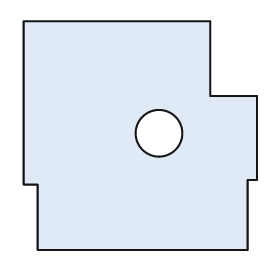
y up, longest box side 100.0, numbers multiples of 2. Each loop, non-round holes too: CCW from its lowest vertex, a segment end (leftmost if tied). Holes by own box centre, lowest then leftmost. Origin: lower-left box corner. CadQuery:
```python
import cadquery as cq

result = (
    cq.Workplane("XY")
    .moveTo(6.0, 0.0)
    .lineTo(96.0, 0.0)
    .lineTo(96.0, 30.0)
    .lineTo(100.0, 30.0)
    .lineTo(100.0, 66.0)
    .lineTo(80.0, 66.0)
    .lineTo(80.0, 98.0)
    .lineTo(0.0, 98.0)
    .lineTo(0.0, 28.0)
    .lineTo(6.0, 28.0)
    .close()
    .moveTo(58.0, 50.0)
    .circle(10.0)
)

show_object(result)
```